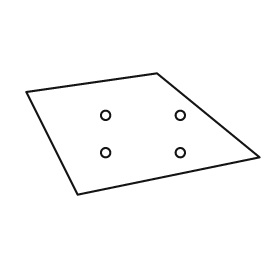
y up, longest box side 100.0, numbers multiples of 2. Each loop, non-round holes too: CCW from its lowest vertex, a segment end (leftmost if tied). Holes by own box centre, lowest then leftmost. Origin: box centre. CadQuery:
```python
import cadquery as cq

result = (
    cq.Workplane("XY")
    .moveTo(-28.0, -26.0)
    .lineTo(50.0, -10.0)
    .lineTo(6.0, 26.0)
    .lineTo(-50.0, 18.0)
    .close()
    .moveTo(-16.0, -8.0)
    .circle(2.0)
    .moveTo(16.0, -8.0)
    .circle(2.0)
    .moveTo(-16.0, 8.0)
    .circle(2.0)
    .moveTo(16.0, 8.0)
    .circle(2.0)
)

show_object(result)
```